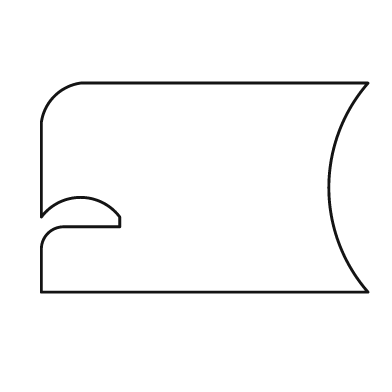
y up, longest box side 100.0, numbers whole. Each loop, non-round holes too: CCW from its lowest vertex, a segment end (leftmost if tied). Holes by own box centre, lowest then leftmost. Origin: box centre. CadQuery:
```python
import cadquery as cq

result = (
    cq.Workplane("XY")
    .moveTo(-50.0, -32.0)
    .lineTo(50.0, -32.0)
    .threePointArc((38.0, 0.0), (50.0, 32.0))
    .lineTo(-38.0, 32.0)
    .threePointArc((-46.0, 28.0), (-50.0, 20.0))
    .lineTo(-50.0, -9.0)
    .threePointArc((-38.0, -3.0), (-26.0, -9.0))
    .lineTo(-26.0, -12.0)
    .lineTo(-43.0, -12.0)
    .threePointArc((-48.0, -14.0), (-50.0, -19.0))
    .close()
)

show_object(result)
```